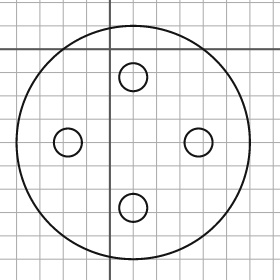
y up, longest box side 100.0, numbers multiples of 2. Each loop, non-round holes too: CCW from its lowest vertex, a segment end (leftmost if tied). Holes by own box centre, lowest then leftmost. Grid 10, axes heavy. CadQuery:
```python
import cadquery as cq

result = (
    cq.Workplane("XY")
    .moveTo(10.0, -40.0)
    .circle(50.0)
    .moveTo(10.0, -68.0)
    .circle(6.0)
    .moveTo(-18.0, -40.0)
    .circle(6.0)
    .moveTo(38.0, -40.0)
    .circle(6.0)
    .moveTo(10.0, -12.0)
    .circle(6.0)
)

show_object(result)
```